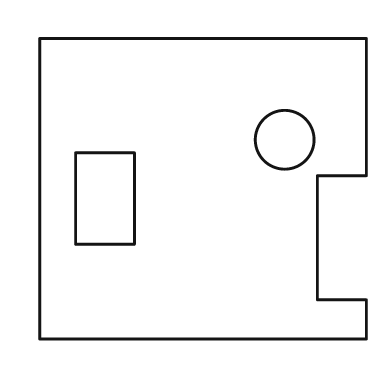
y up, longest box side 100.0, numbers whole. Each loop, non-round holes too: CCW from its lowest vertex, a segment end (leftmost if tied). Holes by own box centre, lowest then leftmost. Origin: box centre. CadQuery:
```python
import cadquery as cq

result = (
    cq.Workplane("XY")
    .moveTo(-50.0, -46.0)
    .lineTo(50.0, -46.0)
    .lineTo(50.0, -34.0)
    .lineTo(35.0, -34.0)
    .lineTo(35.0, 4.0)
    .lineTo(50.0, 4.0)
    .lineTo(50.0, 46.0)
    .lineTo(-50.0, 46.0)
    .close()
    .moveTo(-39.0, -17.0)
    .lineTo(-21.0, -17.0)
    .lineTo(-21.0, 11.0)
    .lineTo(-39.0, 11.0)
    .close()
    .moveTo(25.0, 15.0)
    .circle(9.0)
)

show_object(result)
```